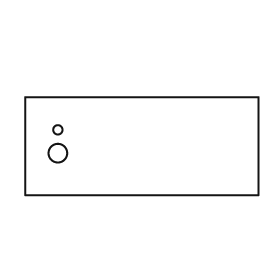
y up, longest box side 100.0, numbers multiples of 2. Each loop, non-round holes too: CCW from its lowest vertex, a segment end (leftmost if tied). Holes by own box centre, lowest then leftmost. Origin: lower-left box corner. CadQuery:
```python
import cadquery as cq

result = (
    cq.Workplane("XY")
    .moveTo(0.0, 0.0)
    .lineTo(100.0, 0.0)
    .lineTo(100.0, 42.0)
    .lineTo(0.0, 42.0)
    .close()
    .moveTo(14.0, 18.0)
    .circle(4.0)
    .moveTo(14.0, 28.0)
    .circle(2.0)
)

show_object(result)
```